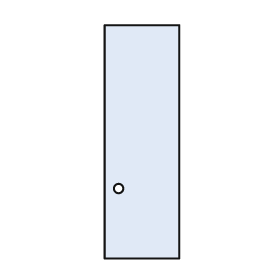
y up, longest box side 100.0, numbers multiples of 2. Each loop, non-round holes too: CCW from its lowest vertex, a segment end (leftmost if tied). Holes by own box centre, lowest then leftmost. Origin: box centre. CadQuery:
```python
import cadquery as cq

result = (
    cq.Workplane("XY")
    .moveTo(-16.0, -50.0)
    .lineTo(16.0, -50.0)
    .lineTo(16.0, 50.0)
    .lineTo(-16.0, 50.0)
    .close()
    .moveTo(-10.0, -20.0)
    .circle(2.0)
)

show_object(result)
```